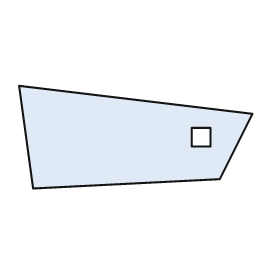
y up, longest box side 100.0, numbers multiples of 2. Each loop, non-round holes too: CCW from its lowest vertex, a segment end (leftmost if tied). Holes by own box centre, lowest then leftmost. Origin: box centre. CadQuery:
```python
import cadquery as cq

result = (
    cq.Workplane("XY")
    .moveTo(-44.0, -22.0)
    .lineTo(36.0, -18.0)
    .lineTo(50.0, 10.0)
    .lineTo(-50.0, 22.0)
    .close()
    .moveTo(24.0, -4.0)
    .lineTo(32.0, -4.0)
    .lineTo(32.0, 4.0)
    .lineTo(24.0, 4.0)
    .close()
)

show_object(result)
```